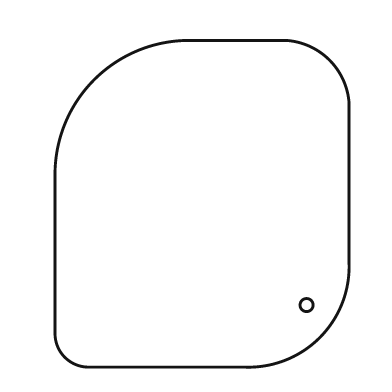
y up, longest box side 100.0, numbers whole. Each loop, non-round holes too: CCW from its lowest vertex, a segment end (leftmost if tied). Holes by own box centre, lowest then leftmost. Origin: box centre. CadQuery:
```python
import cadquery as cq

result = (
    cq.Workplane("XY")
    .moveTo(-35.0, -50.0)
    .lineTo(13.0, -50.0)
    .threePointArc((36.0, -41.0), (45.0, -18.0))
    .lineTo(45.0, 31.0)
    .threePointArc((39.0, 44.0), (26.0, 50.0))
    .lineTo(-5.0, 50.0)
    .threePointArc((-33.0, 38.0), (-45.0, 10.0))
    .lineTo(-45.0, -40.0)
    .threePointArc((-42.0, -47.0), (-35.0, -50.0))
    .close()
    .moveTo(32.0, -31.0)
    .circle(2.0)
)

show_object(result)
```